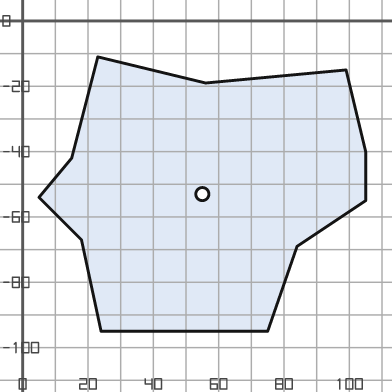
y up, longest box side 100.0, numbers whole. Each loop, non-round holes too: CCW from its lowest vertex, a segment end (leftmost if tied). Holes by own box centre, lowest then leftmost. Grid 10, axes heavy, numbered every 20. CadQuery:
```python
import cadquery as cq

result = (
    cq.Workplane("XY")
    .moveTo(24.0, -95.0)
    .lineTo(75.0, -95.0)
    .lineTo(84.0, -69.0)
    .lineTo(105.0, -55.0)
    .lineTo(105.0, -40.0)
    .lineTo(99.0, -15.0)
    .lineTo(56.0, -19.0)
    .lineTo(23.0, -11.0)
    .lineTo(15.0, -42.0)
    .lineTo(5.0, -54.0)
    .lineTo(18.0, -67.0)
    .close()
    .moveTo(55.0, -53.0)
    .circle(2.0)
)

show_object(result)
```